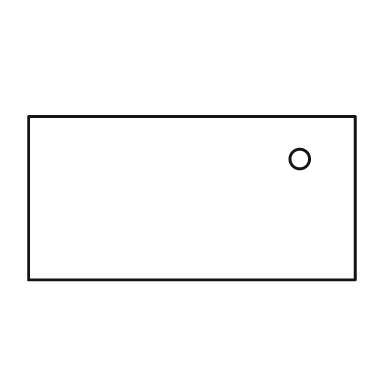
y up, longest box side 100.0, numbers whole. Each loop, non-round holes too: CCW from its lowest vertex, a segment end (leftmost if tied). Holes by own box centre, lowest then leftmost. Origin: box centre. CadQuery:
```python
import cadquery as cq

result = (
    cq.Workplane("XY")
    .moveTo(-50.0, -25.0)
    .lineTo(50.0, -25.0)
    .lineTo(50.0, 25.0)
    .lineTo(-50.0, 25.0)
    .close()
    .moveTo(33.0, 12.0)
    .circle(3.0)
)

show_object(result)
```